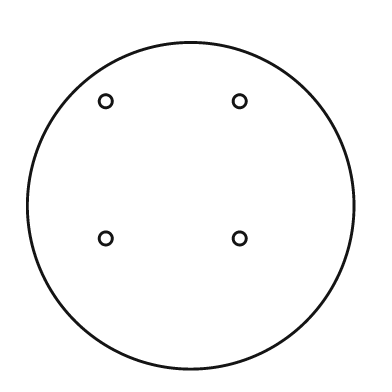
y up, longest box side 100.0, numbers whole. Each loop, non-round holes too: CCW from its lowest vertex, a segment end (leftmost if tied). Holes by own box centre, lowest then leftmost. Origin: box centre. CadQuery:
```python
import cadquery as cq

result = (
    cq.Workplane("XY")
    .moveTo(0.0, 0.0)
    .circle(50.0)
    .moveTo(-26.0, -10.0)
    .circle(2.0)
    .moveTo(15.0, -10.0)
    .circle(2.0)
    .moveTo(-26.0, 32.0)
    .circle(2.0)
    .moveTo(15.0, 32.0)
    .circle(2.0)
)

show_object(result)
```